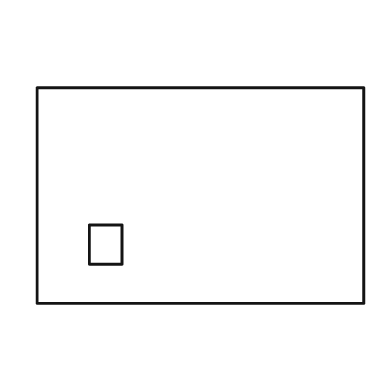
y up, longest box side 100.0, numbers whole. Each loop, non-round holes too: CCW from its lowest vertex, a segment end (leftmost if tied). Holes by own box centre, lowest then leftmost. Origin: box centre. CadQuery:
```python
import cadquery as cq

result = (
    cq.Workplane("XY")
    .moveTo(-50.0, -33.0)
    .lineTo(50.0, -33.0)
    .lineTo(50.0, 33.0)
    .lineTo(-50.0, 33.0)
    .close()
    .moveTo(-34.0, -21.0)
    .lineTo(-24.0, -21.0)
    .lineTo(-24.0, -9.0)
    .lineTo(-34.0, -9.0)
    .close()
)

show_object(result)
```